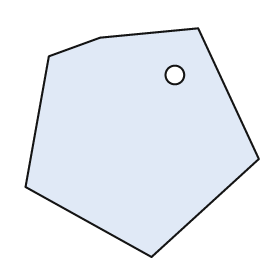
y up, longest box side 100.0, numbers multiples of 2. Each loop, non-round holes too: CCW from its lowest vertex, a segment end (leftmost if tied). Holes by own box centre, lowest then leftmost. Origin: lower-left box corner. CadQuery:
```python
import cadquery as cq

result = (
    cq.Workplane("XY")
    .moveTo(54.0, 0.0)
    .lineTo(100.0, 42.0)
    .lineTo(74.0, 98.0)
    .lineTo(32.0, 94.0)
    .lineTo(10.0, 86.0)
    .lineTo(0.0, 30.0)
    .close()
    .moveTo(64.0, 78.0)
    .circle(4.0)
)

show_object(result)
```